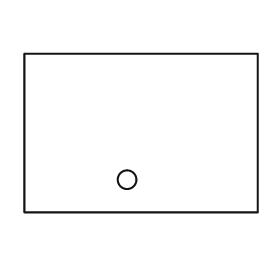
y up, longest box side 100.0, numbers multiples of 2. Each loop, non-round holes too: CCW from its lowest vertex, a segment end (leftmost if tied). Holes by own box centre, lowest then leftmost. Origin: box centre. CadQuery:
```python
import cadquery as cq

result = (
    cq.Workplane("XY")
    .moveTo(-50.0, -34.0)
    .lineTo(50.0, -34.0)
    .lineTo(50.0, 34.0)
    .lineTo(-50.0, 34.0)
    .close()
    .moveTo(-6.0, -20.0)
    .circle(4.0)
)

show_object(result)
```